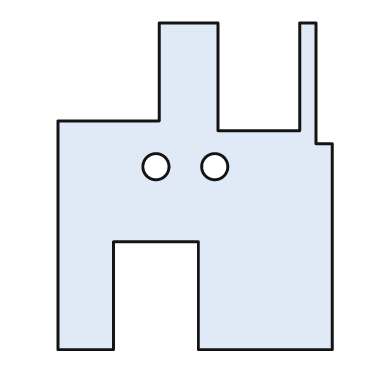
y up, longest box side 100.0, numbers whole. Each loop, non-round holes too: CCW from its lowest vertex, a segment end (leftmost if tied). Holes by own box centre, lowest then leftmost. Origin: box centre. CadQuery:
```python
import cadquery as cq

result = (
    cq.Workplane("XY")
    .moveTo(-42.0, -50.0)
    .lineTo(-25.0, -50.0)
    .lineTo(-25.0, -17.0)
    .lineTo(1.0, -17.0)
    .lineTo(1.0, -50.0)
    .lineTo(42.0, -50.0)
    .lineTo(42.0, 13.0)
    .lineTo(37.0, 13.0)
    .lineTo(37.0, 50.0)
    .lineTo(32.0, 50.0)
    .lineTo(32.0, 17.0)
    .lineTo(7.0, 17.0)
    .lineTo(7.0, 50.0)
    .lineTo(-11.0, 50.0)
    .lineTo(-11.0, 20.0)
    .lineTo(-42.0, 20.0)
    .close()
    .moveTo(-12.0, 6.0)
    .circle(4.0)
    .moveTo(6.0, 6.0)
    .circle(4.0)
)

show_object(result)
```